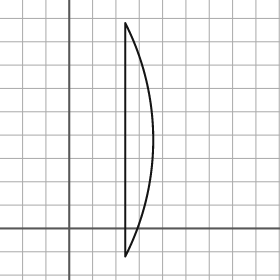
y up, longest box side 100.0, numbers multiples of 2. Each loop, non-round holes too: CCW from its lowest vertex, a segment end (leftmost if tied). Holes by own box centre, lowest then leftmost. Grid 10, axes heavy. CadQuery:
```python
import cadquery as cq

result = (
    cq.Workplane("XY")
    .moveTo(24.0, -12.0)
    .threePointArc((36.0, 38.0), (24.0, 88.0))
    .close()
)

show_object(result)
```